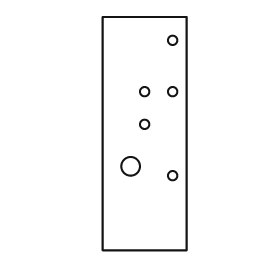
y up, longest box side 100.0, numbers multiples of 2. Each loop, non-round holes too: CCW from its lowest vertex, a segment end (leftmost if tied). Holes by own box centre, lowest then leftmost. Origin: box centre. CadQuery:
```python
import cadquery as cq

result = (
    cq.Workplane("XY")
    .moveTo(-18.0, -50.0)
    .lineTo(18.0, -50.0)
    .lineTo(18.0, 50.0)
    .lineTo(-18.0, 50.0)
    .close()
    .moveTo(12.0, -18.0)
    .circle(2.0)
    .moveTo(-6.0, -14.0)
    .circle(4.0)
    .moveTo(0.0, 4.0)
    .circle(2.0)
    .moveTo(0.0, 18.0)
    .circle(2.0)
    .moveTo(12.0, 18.0)
    .circle(2.0)
    .moveTo(12.0, 40.0)
    .circle(2.0)
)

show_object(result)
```